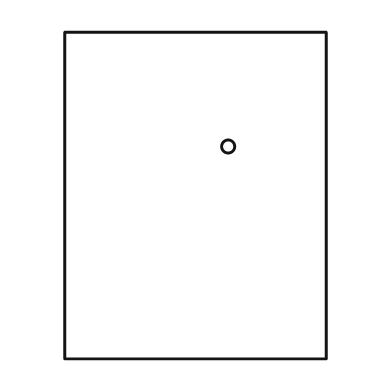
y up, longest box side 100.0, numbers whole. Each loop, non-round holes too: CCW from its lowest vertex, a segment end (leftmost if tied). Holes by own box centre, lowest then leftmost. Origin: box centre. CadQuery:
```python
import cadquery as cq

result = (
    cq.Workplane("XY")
    .moveTo(-40.0, -50.0)
    .lineTo(40.0, -50.0)
    .lineTo(40.0, 50.0)
    .lineTo(-40.0, 50.0)
    .close()
    .moveTo(10.0, 15.0)
    .circle(2.0)
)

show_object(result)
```